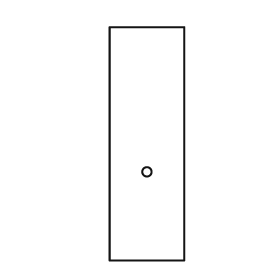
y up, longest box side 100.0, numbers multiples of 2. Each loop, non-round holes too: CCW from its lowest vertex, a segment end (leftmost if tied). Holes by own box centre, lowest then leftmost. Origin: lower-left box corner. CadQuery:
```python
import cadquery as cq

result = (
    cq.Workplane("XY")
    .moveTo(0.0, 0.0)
    .lineTo(32.0, 0.0)
    .lineTo(32.0, 100.0)
    .lineTo(0.0, 100.0)
    .close()
    .moveTo(16.0, 38.0)
    .circle(2.0)
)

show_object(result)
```